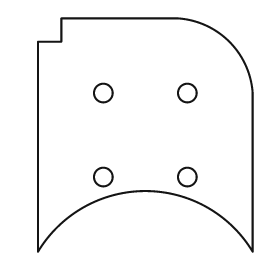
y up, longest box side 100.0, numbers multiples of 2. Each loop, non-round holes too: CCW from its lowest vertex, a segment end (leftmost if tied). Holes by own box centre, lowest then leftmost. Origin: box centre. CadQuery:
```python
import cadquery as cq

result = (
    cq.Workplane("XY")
    .moveTo(-46.0, -50.0)
    .threePointArc((0.0, -24.0), (46.0, -50.0))
    .lineTo(46.0, 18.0)
    .threePointArc((36.0, 40.0), (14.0, 50.0))
    .lineTo(-36.0, 50.0)
    .lineTo(-36.0, 40.0)
    .lineTo(-46.0, 40.0)
    .close()
    .moveTo(-18.0, -18.0)
    .circle(4.0)
    .moveTo(18.0, -18.0)
    .circle(4.0)
    .moveTo(-18.0, 18.0)
    .circle(4.0)
    .moveTo(18.0, 18.0)
    .circle(4.0)
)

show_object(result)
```